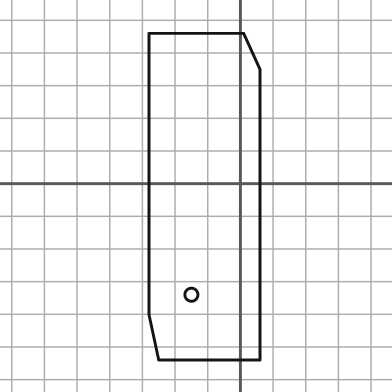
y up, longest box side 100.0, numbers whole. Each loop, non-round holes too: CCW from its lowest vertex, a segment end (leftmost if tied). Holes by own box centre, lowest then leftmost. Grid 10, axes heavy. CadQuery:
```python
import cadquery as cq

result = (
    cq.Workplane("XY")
    .moveTo(-25.0, -54.0)
    .lineTo(6.0, -54.0)
    .lineTo(6.0, 35.0)
    .lineTo(1.0, 46.0)
    .lineTo(-28.0, 46.0)
    .lineTo(-28.0, -40.0)
    .close()
    .moveTo(-15.0, -34.0)
    .circle(2.0)
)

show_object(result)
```